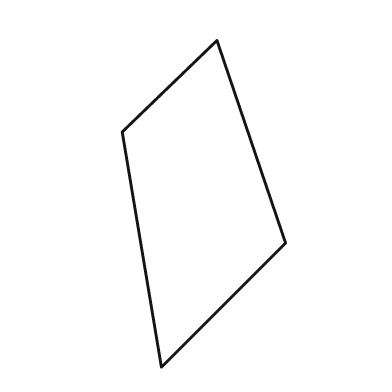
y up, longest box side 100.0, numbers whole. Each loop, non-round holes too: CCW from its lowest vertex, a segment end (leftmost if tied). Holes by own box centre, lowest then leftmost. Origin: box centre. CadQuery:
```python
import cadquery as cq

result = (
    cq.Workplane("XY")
    .moveTo(-13.0, -50.0)
    .lineTo(25.0, -12.0)
    .lineTo(4.0, 50.0)
    .lineTo(-25.0, 22.0)
    .close()
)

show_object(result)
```